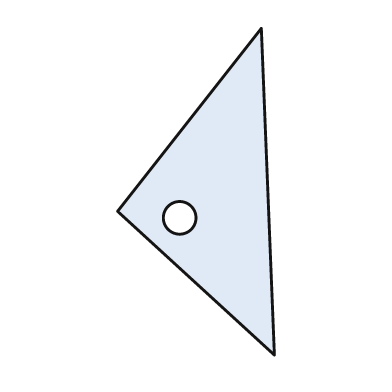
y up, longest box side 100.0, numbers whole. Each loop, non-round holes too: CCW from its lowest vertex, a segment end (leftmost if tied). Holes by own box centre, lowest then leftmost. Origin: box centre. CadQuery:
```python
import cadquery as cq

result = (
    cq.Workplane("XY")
    .moveTo(24.0, -50.0)
    .lineTo(20.0, 50.0)
    .lineTo(-24.0, -6.0)
    .close()
    .moveTo(-5.0, -8.0)
    .circle(5.0)
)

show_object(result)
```